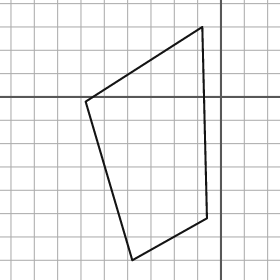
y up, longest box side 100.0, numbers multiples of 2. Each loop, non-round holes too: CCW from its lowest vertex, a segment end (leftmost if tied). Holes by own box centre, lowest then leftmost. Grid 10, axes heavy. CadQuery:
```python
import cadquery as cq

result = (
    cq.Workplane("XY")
    .moveTo(-38.0, -70.0)
    .lineTo(-6.0, -52.0)
    .lineTo(-8.0, 30.0)
    .lineTo(-58.0, -2.0)
    .close()
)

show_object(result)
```